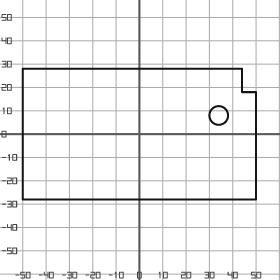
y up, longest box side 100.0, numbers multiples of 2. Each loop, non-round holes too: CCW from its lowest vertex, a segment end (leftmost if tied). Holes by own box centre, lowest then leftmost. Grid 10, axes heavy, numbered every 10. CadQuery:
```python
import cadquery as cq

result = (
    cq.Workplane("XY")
    .moveTo(-50.0, -28.0)
    .lineTo(50.0, -28.0)
    .lineTo(50.0, 18.0)
    .lineTo(44.0, 18.0)
    .lineTo(44.0, 28.0)
    .lineTo(-50.0, 28.0)
    .close()
    .moveTo(34.0, 8.0)
    .circle(4.0)
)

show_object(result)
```